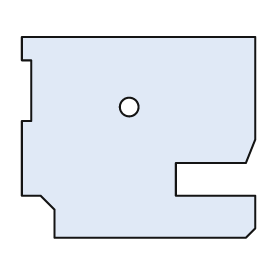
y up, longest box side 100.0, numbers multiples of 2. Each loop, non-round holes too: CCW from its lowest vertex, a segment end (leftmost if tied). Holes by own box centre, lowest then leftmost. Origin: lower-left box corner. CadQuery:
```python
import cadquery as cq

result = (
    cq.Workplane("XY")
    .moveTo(14.0, 0.0)
    .lineTo(96.0, 0.0)
    .lineTo(100.0, 4.0)
    .lineTo(100.0, 18.0)
    .lineTo(66.0, 18.0)
    .lineTo(66.0, 32.0)
    .lineTo(96.0, 32.0)
    .lineTo(100.0, 42.0)
    .lineTo(100.0, 86.0)
    .lineTo(0.0, 86.0)
    .lineTo(0.0, 76.0)
    .lineTo(4.0, 76.0)
    .lineTo(4.0, 50.0)
    .lineTo(0.0, 50.0)
    .lineTo(0.0, 18.0)
    .lineTo(8.0, 18.0)
    .lineTo(14.0, 12.0)
    .close()
    .moveTo(46.0, 56.0)
    .circle(4.0)
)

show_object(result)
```